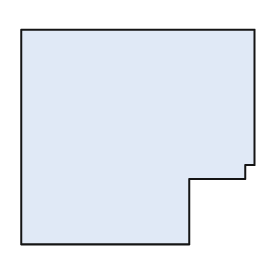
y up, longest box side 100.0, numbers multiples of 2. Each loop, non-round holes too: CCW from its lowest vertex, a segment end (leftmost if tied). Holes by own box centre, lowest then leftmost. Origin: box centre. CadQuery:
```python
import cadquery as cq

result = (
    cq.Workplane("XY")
    .moveTo(-50.0, -46.0)
    .lineTo(22.0, -46.0)
    .lineTo(22.0, -18.0)
    .lineTo(46.0, -18.0)
    .lineTo(46.0, -12.0)
    .lineTo(50.0, -12.0)
    .lineTo(50.0, 46.0)
    .lineTo(-50.0, 46.0)
    .close()
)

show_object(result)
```